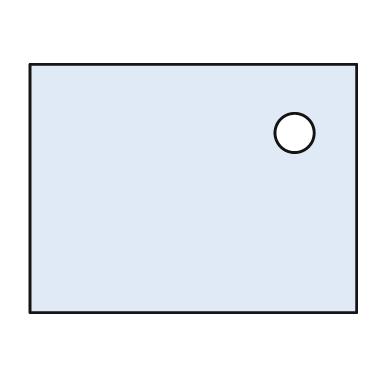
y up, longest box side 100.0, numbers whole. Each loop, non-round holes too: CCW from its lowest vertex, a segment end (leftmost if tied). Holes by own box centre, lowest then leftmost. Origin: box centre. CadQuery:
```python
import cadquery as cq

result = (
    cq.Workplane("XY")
    .moveTo(-50.0, -38.0)
    .lineTo(50.0, -38.0)
    .lineTo(50.0, 38.0)
    .lineTo(-50.0, 38.0)
    .close()
    .moveTo(31.0, 17.0)
    .circle(6.0)
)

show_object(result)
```